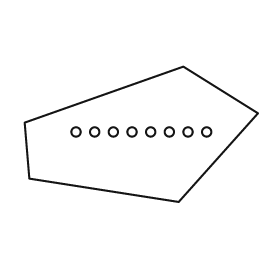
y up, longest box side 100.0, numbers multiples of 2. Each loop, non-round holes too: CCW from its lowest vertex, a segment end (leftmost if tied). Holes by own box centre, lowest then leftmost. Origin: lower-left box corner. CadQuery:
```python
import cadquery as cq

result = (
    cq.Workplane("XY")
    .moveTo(66.0, 0.0)
    .lineTo(100.0, 38.0)
    .lineTo(68.0, 58.0)
    .lineTo(0.0, 34.0)
    .lineTo(2.0, 10.0)
    .close()
    .moveTo(22.0, 30.0)
    .circle(2.0)
    .moveTo(30.0, 30.0)
    .circle(2.0)
    .moveTo(38.0, 30.0)
    .circle(2.0)
    .moveTo(46.0, 30.0)
    .circle(2.0)
    .moveTo(54.0, 30.0)
    .circle(2.0)
    .moveTo(62.0, 30.0)
    .circle(2.0)
    .moveTo(70.0, 30.0)
    .circle(2.0)
    .moveTo(78.0, 30.0)
    .circle(2.0)
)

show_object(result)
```